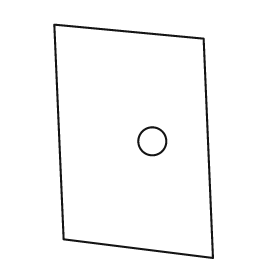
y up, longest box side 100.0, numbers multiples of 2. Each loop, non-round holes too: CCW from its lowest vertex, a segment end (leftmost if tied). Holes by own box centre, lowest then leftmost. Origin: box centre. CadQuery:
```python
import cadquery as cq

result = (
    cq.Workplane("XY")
    .moveTo(34.0, -50.0)
    .lineTo(30.0, 44.0)
    .lineTo(-34.0, 50.0)
    .lineTo(-30.0, -42.0)
    .close()
    .moveTo(8.0, 0.0)
    .circle(6.0)
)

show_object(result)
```